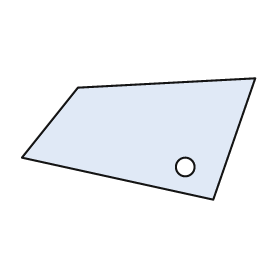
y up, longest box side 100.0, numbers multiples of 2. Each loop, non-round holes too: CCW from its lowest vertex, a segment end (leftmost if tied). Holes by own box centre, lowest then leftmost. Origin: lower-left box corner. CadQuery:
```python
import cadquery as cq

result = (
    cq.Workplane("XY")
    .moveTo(82.0, 0.0)
    .lineTo(100.0, 52.0)
    .lineTo(24.0, 48.0)
    .lineTo(0.0, 18.0)
    .close()
    .moveTo(70.0, 14.0)
    .circle(4.0)
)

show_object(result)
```